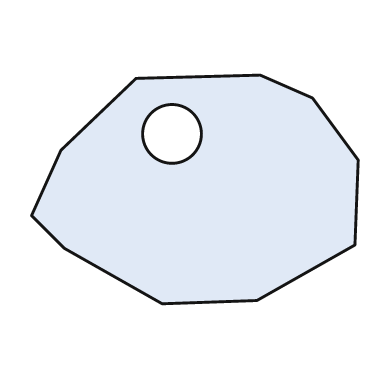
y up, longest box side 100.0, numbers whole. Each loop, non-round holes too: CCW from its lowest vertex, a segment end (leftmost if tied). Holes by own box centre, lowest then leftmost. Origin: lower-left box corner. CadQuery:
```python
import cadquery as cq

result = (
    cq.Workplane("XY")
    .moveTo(40.0, 0.0)
    .lineTo(69.0, 1.0)
    .lineTo(99.0, 18.0)
    .lineTo(100.0, 44.0)
    .lineTo(86.0, 63.0)
    .lineTo(70.0, 70.0)
    .lineTo(32.0, 69.0)
    .lineTo(9.0, 47.0)
    .lineTo(0.0, 27.0)
    .lineTo(10.0, 17.0)
    .close()
    .moveTo(43.0, 52.0)
    .circle(9.0)
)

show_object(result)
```